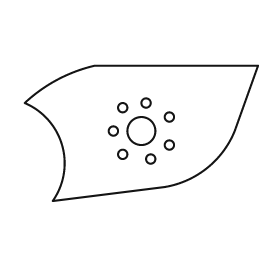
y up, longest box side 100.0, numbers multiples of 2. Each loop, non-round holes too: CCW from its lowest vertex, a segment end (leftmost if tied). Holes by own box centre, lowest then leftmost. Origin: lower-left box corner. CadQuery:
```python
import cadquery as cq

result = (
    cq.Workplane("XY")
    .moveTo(12.0, 0.0)
    .lineTo(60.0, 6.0)
    .threePointArc((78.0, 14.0), (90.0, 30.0))
    .lineTo(100.0, 58.0)
    .lineTo(30.0, 58.0)
    .threePointArc((14.0, 52.0), (0.0, 42.0))
    .threePointArc((16.0, 24.0), (12.0, 0.0))
    .close()
    .moveTo(54.0, 18.0)
    .circle(2.0)
    .moveTo(42.0, 20.0)
    .circle(2.0)
    .moveTo(62.0, 24.0)
    .circle(2.0)
    .moveTo(38.0, 30.0)
    .circle(2.0)
    .moveTo(50.0, 30.0)
    .circle(6.0)
    .moveTo(62.0, 36.0)
    .circle(2.0)
    .moveTo(42.0, 40.0)
    .circle(2.0)
    .moveTo(52.0, 42.0)
    .circle(2.0)
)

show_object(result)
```